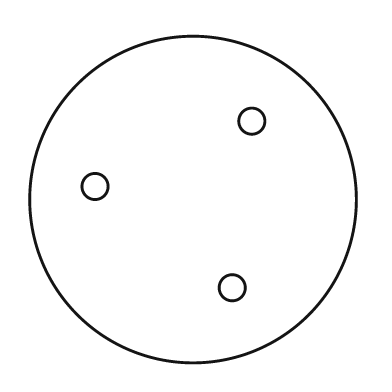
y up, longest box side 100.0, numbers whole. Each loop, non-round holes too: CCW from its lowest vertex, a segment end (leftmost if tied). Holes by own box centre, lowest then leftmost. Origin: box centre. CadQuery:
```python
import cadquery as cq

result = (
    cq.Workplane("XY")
    .moveTo(0.0, 0.0)
    .circle(50.0)
    .moveTo(12.0, -27.0)
    .circle(4.0)
    .moveTo(-30.0, 4.0)
    .circle(4.0)
    .moveTo(18.0, 24.0)
    .circle(4.0)
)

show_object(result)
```